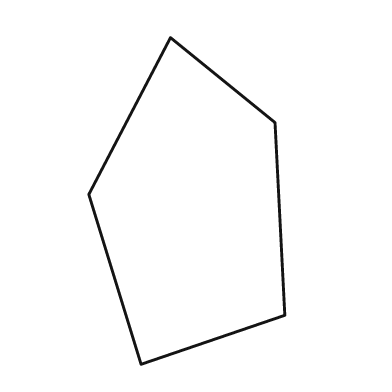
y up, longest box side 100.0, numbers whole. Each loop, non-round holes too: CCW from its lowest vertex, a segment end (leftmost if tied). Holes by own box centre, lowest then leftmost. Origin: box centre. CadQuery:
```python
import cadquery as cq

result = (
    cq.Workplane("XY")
    .moveTo(-14.0, -50.0)
    .lineTo(30.0, -35.0)
    .lineTo(27.0, 24.0)
    .lineTo(-5.0, 50.0)
    .lineTo(-30.0, 2.0)
    .close()
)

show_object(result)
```